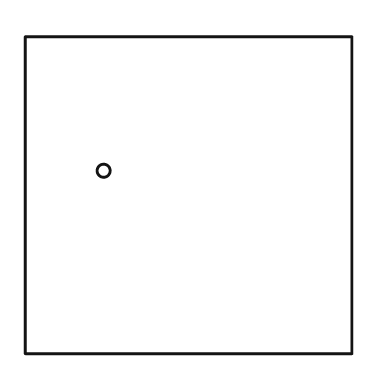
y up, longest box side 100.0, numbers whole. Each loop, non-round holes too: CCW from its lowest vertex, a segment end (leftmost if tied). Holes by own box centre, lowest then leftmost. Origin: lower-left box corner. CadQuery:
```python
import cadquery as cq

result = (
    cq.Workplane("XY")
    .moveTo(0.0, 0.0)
    .lineTo(100.0, 0.0)
    .lineTo(100.0, 97.0)
    .lineTo(0.0, 97.0)
    .close()
    .moveTo(24.0, 56.0)
    .circle(2.0)
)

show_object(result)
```